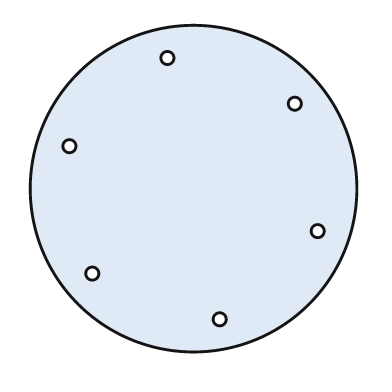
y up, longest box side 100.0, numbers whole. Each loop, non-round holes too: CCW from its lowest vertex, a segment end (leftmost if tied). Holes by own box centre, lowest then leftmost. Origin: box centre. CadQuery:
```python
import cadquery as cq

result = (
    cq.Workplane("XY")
    .moveTo(0.0, 0.0)
    .circle(50.0)
    .moveTo(8.0, -40.0)
    .circle(2.0)
    .moveTo(-31.0, -26.0)
    .circle(2.0)
    .moveTo(38.0, -13.0)
    .circle(2.0)
    .moveTo(-38.0, 13.0)
    .circle(2.0)
    .moveTo(31.0, 26.0)
    .circle(2.0)
    .moveTo(-8.0, 40.0)
    .circle(2.0)
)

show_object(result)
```